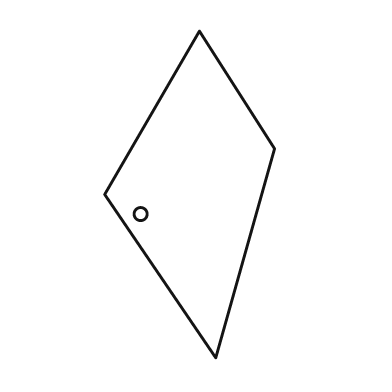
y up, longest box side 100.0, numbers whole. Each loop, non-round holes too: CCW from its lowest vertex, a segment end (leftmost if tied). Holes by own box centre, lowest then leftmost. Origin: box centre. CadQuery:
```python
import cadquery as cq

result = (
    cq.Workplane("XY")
    .moveTo(8.0, -50.0)
    .lineTo(26.0, 14.0)
    .lineTo(3.0, 50.0)
    .lineTo(-26.0, 0.0)
    .close()
    .moveTo(-15.0, -6.0)
    .circle(2.0)
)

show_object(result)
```